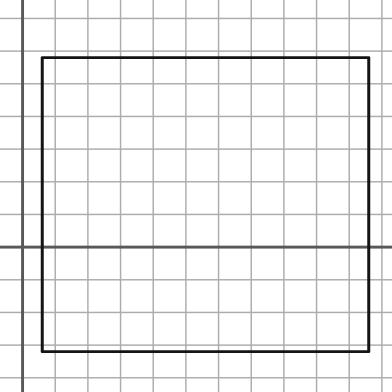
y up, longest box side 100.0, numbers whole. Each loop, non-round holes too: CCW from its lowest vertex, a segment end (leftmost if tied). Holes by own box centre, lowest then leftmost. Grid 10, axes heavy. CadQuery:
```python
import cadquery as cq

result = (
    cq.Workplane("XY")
    .moveTo(6.0, -32.0)
    .lineTo(106.0, -32.0)
    .lineTo(106.0, 58.0)
    .lineTo(6.0, 58.0)
    .close()
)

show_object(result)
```